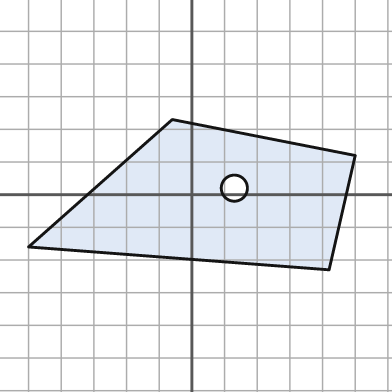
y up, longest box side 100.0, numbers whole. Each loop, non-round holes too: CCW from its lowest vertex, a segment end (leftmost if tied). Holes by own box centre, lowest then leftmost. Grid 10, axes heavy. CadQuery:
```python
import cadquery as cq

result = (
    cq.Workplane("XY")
    .moveTo(42.0, -23.0)
    .lineTo(50.0, 12.0)
    .lineTo(-6.0, 23.0)
    .lineTo(-50.0, -16.0)
    .close()
    .moveTo(13.0, 2.0)
    .circle(4.0)
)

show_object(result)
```